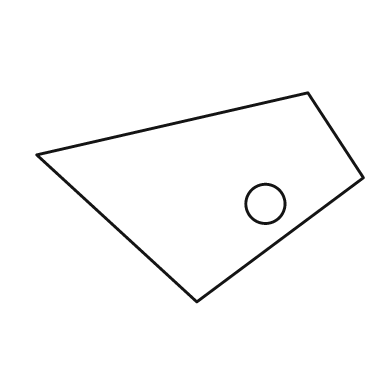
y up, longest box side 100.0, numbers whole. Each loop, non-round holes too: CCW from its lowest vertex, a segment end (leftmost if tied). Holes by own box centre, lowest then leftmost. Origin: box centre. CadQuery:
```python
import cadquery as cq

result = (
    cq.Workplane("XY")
    .moveTo(-1.0, -32.0)
    .lineTo(50.0, 6.0)
    .lineTo(33.0, 32.0)
    .lineTo(-50.0, 13.0)
    .close()
    .moveTo(20.0, -2.0)
    .circle(6.0)
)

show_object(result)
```